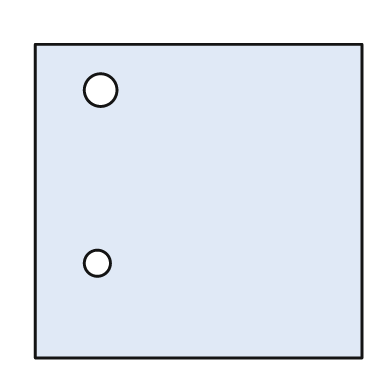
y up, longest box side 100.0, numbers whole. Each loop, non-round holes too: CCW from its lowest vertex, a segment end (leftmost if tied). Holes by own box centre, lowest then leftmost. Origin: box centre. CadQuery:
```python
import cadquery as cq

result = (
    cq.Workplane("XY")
    .moveTo(-50.0, -48.0)
    .lineTo(50.0, -48.0)
    .lineTo(50.0, 48.0)
    .lineTo(-50.0, 48.0)
    .close()
    .moveTo(-31.0, -19.0)
    .circle(4.0)
    .moveTo(-30.0, 34.0)
    .circle(5.0)
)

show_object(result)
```